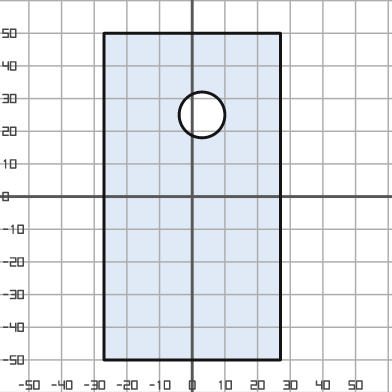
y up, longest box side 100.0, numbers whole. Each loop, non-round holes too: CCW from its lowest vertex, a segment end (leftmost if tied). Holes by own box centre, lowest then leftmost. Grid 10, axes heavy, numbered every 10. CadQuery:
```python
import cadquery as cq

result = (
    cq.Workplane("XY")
    .moveTo(-27.0, -50.0)
    .lineTo(27.0, -50.0)
    .lineTo(27.0, 50.0)
    .lineTo(-27.0, 50.0)
    .close()
    .moveTo(3.0, 25.0)
    .circle(7.0)
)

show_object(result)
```